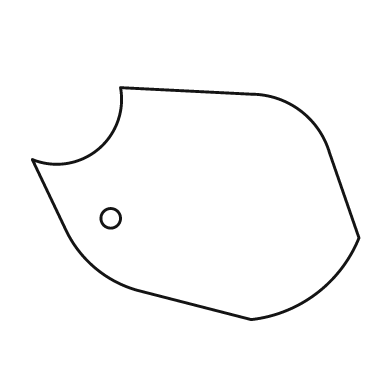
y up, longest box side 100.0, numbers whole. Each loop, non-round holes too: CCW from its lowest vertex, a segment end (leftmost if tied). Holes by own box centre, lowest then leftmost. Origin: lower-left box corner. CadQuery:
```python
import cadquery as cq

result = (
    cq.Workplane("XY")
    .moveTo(67.0, 0.0)
    .threePointArc((87.0, 8.0), (100.0, 25.0))
    .lineTo(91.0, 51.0)
    .threePointArc((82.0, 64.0), (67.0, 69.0))
    .lineTo(27.0, 71.0)
    .threePointArc((20.0, 52.0), (0.0, 49.0))
    .lineTo(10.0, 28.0)
    .threePointArc((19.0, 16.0), (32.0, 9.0))
    .close()
    .moveTo(24.0, 31.0)
    .circle(3.0)
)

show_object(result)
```